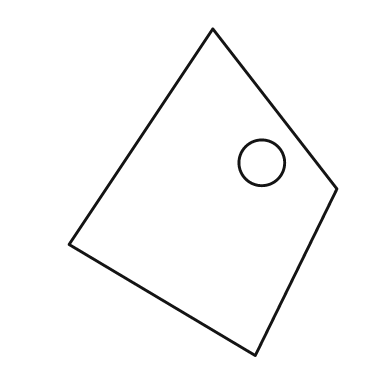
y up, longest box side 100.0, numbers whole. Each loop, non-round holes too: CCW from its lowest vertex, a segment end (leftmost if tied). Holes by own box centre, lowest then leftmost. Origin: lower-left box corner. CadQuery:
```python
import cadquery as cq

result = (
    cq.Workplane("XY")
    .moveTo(57.0, 0.0)
    .lineTo(82.0, 51.0)
    .lineTo(44.0, 100.0)
    .lineTo(0.0, 34.0)
    .close()
    .moveTo(59.0, 59.0)
    .circle(7.0)
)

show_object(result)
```